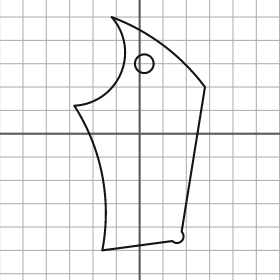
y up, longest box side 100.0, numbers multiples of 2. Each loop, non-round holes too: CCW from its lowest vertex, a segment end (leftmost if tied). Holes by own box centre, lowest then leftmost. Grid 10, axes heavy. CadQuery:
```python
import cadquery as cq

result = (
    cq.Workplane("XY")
    .moveTo(-16.0, -50.0)
    .lineTo(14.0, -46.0)
    .threePointArc((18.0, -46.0), (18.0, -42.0))
    .lineTo(28.0, 20.0)
    .threePointArc((10.0, 38.0), (-12.0, 50.0))
    .threePointArc((-8.0, 26.0), (-28.0, 12.0))
    .threePointArc((-16.0, -18.0), (-16.0, -50.0))
    .close()
    .moveTo(2.0, 30.0)
    .circle(4.0)
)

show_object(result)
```